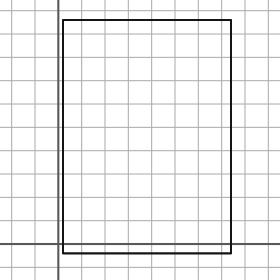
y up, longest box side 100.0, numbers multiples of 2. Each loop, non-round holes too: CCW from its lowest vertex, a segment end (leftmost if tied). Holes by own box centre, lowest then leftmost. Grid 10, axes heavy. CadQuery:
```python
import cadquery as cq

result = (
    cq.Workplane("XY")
    .moveTo(2.0, -4.0)
    .lineTo(74.0, -4.0)
    .lineTo(74.0, 96.0)
    .lineTo(2.0, 96.0)
    .close()
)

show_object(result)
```